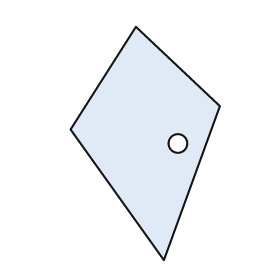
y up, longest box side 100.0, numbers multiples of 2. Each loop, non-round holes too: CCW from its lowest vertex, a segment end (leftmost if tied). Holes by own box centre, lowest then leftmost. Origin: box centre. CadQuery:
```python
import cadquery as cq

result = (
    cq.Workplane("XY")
    .moveTo(8.0, -50.0)
    .lineTo(32.0, 16.0)
    .lineTo(-4.0, 50.0)
    .lineTo(-32.0, 6.0)
    .close()
    .moveTo(14.0, 0.0)
    .circle(4.0)
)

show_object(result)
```